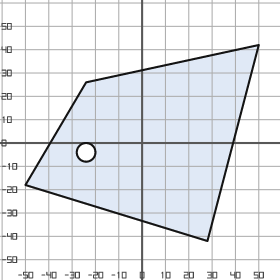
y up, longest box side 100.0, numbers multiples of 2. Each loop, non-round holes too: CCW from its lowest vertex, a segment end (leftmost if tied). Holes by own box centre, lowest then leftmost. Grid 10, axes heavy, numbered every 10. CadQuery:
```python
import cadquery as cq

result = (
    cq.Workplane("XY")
    .moveTo(28.0, -42.0)
    .lineTo(50.0, 42.0)
    .lineTo(-24.0, 26.0)
    .lineTo(-50.0, -18.0)
    .close()
    .moveTo(-24.0, -4.0)
    .circle(4.0)
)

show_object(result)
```